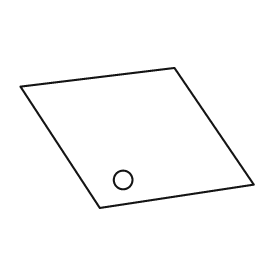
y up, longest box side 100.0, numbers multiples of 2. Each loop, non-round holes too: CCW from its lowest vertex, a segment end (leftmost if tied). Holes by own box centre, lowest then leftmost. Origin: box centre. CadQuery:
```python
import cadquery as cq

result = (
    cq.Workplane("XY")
    .moveTo(-16.0, -30.0)
    .lineTo(50.0, -20.0)
    .lineTo(16.0, 30.0)
    .lineTo(-50.0, 22.0)
    .close()
    .moveTo(-6.0, -18.0)
    .circle(4.0)
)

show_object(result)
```